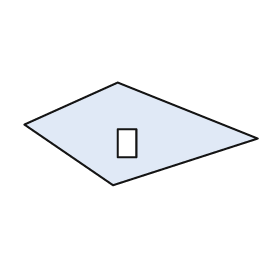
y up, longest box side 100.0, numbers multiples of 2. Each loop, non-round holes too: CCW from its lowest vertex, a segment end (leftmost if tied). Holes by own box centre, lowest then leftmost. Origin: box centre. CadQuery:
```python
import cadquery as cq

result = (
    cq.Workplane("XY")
    .moveTo(-12.0, -22.0)
    .lineTo(50.0, -2.0)
    .lineTo(-10.0, 22.0)
    .lineTo(-50.0, 4.0)
    .close()
    .moveTo(-10.0, -10.0)
    .lineTo(-2.0, -10.0)
    .lineTo(-2.0, 2.0)
    .lineTo(-10.0, 2.0)
    .close()
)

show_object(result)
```